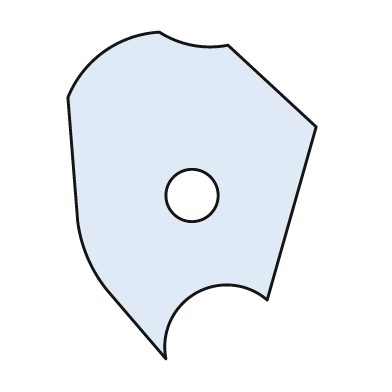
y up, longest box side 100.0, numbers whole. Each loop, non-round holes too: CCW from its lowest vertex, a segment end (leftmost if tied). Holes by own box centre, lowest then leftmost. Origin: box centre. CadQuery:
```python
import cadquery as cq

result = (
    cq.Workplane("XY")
    .moveTo(-8.0, -50.0)
    .threePointArc((1.0, -30.0), (23.0, -32.0))
    .lineTo(38.0, 21.0)
    .lineTo(11.0, 46.0)
    .threePointArc((0.0, 46.0), (-10.0, 50.0))
    .threePointArc((-27.0, 44.0), (-38.0, 30.0))
    .lineTo(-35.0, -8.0)
    .threePointArc((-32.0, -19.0), (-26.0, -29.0))
    .close()
    .moveTo(0.0, 0.0)
    .circle(8.0)
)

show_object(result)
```